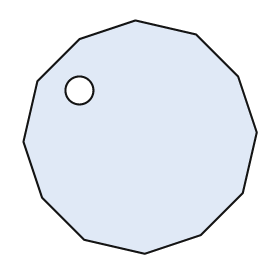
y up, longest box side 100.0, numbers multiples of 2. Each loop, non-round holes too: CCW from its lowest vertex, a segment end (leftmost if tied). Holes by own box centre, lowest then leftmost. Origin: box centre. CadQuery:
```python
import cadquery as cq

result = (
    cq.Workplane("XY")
    .moveTo(2.0, -50.0)
    .lineTo(26.0, -42.0)
    .lineTo(44.0, -24.0)
    .lineTo(50.0, 2.0)
    .lineTo(42.0, 26.0)
    .lineTo(24.0, 44.0)
    .lineTo(-2.0, 50.0)
    .lineTo(-26.0, 42.0)
    .lineTo(-44.0, 24.0)
    .lineTo(-50.0, -2.0)
    .lineTo(-42.0, -26.0)
    .lineTo(-24.0, -44.0)
    .close()
    .moveTo(-26.0, 20.0)
    .circle(6.0)
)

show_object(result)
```